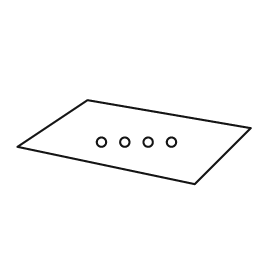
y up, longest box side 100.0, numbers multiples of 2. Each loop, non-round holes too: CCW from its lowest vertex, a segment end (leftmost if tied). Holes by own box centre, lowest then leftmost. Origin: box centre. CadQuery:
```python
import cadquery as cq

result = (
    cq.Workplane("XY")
    .moveTo(26.0, -18.0)
    .lineTo(50.0, 6.0)
    .lineTo(-20.0, 18.0)
    .lineTo(-50.0, -2.0)
    .close()
    .moveTo(-14.0, 0.0)
    .circle(2.0)
    .moveTo(-4.0, 0.0)
    .circle(2.0)
    .moveTo(6.0, 0.0)
    .circle(2.0)
    .moveTo(16.0, 0.0)
    .circle(2.0)
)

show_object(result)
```